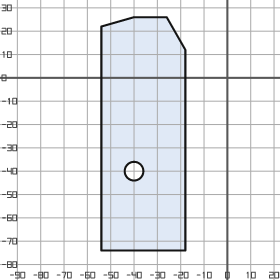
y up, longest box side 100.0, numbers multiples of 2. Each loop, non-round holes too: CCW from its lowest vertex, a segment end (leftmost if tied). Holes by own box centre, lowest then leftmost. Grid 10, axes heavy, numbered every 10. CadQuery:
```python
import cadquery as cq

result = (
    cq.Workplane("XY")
    .moveTo(-54.0, -74.0)
    .lineTo(-18.0, -74.0)
    .lineTo(-18.0, 12.0)
    .lineTo(-26.0, 26.0)
    .lineTo(-40.0, 26.0)
    .lineTo(-54.0, 22.0)
    .close()
    .moveTo(-40.0, -40.0)
    .circle(4.0)
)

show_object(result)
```